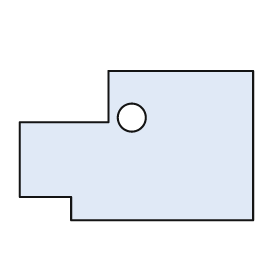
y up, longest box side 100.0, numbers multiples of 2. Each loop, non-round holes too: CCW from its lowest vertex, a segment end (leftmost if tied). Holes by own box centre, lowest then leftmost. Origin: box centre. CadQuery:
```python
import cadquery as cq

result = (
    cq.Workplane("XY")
    .moveTo(-28.0, -32.0)
    .lineTo(50.0, -32.0)
    .lineTo(50.0, 32.0)
    .lineTo(-12.0, 32.0)
    .lineTo(-12.0, 10.0)
    .lineTo(-50.0, 10.0)
    .lineTo(-50.0, -22.0)
    .lineTo(-28.0, -22.0)
    .close()
    .moveTo(-2.0, 12.0)
    .circle(6.0)
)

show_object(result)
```